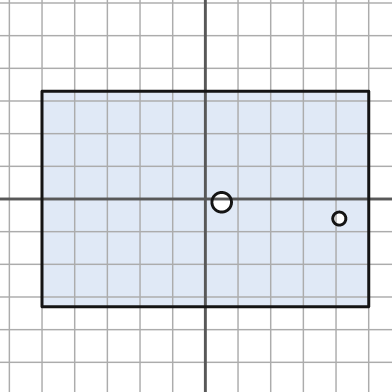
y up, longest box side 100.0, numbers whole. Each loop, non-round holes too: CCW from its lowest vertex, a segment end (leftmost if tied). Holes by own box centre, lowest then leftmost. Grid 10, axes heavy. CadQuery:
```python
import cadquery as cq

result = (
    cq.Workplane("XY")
    .moveTo(-50.0, -33.0)
    .lineTo(50.0, -33.0)
    .lineTo(50.0, 33.0)
    .lineTo(-50.0, 33.0)
    .close()
    .moveTo(41.0, -6.0)
    .circle(2.0)
    .moveTo(5.0, -1.0)
    .circle(3.0)
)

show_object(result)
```